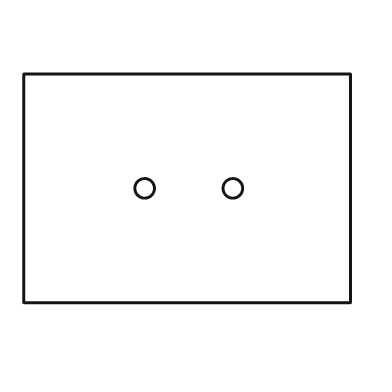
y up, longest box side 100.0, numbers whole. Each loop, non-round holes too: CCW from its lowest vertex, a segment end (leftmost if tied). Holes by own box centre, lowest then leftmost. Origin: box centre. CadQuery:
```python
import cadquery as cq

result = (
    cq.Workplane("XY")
    .moveTo(-50.0, -35.0)
    .lineTo(50.0, -35.0)
    .lineTo(50.0, 35.0)
    .lineTo(-50.0, 35.0)
    .close()
    .moveTo(-13.0, 0.0)
    .circle(3.0)
    .moveTo(14.0, 0.0)
    .circle(3.0)
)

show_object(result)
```